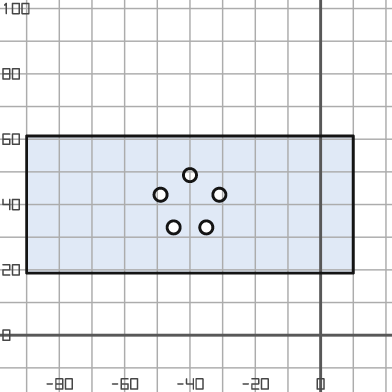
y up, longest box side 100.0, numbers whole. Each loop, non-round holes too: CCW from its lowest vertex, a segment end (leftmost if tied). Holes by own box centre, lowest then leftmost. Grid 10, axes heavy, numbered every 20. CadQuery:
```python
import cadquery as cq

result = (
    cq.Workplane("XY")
    .moveTo(-90.0, 19.0)
    .lineTo(10.0, 19.0)
    .lineTo(10.0, 61.0)
    .lineTo(-90.0, 61.0)
    .close()
    .moveTo(-45.0, 33.0)
    .circle(2.0)
    .moveTo(-35.0, 33.0)
    .circle(2.0)
    .moveTo(-49.0, 43.0)
    .circle(2.0)
    .moveTo(-31.0, 43.0)
    .circle(2.0)
    .moveTo(-40.0, 49.0)
    .circle(2.0)
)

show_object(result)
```